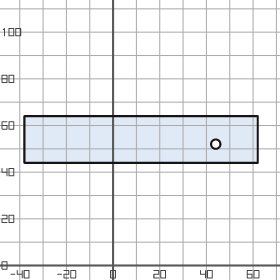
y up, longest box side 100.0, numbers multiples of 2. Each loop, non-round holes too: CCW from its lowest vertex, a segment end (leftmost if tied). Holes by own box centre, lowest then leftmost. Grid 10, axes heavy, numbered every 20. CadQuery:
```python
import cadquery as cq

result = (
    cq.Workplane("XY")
    .moveTo(-38.0, 44.0)
    .lineTo(62.0, 44.0)
    .lineTo(62.0, 64.0)
    .lineTo(-38.0, 64.0)
    .close()
    .moveTo(44.0, 52.0)
    .circle(2.0)
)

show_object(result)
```